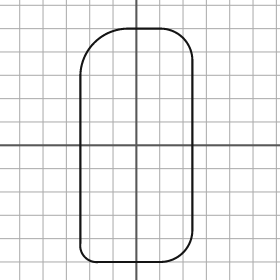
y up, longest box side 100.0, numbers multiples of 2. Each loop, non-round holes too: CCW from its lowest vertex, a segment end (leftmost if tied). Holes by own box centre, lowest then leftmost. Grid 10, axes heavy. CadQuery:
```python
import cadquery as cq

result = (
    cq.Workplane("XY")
    .moveTo(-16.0, -50.0)
    .lineTo(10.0, -50.0)
    .threePointArc((20.0, -46.0), (24.0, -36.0))
    .lineTo(24.0, 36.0)
    .threePointArc((20.0, 46.0), (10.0, 50.0))
    .lineTo(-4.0, 50.0)
    .threePointArc((-18.0, 44.0), (-24.0, 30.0))
    .lineTo(-24.0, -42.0)
    .threePointArc((-22.0, -48.0), (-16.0, -50.0))
    .close()
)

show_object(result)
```